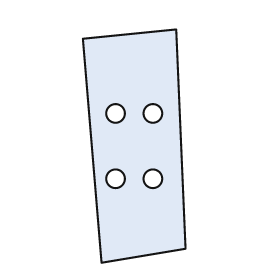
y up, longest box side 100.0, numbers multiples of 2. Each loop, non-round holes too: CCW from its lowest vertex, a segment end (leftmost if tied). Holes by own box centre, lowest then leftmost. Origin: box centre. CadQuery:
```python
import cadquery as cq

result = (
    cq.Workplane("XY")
    .moveTo(-14.0, -50.0)
    .lineTo(22.0, -44.0)
    .lineTo(18.0, 50.0)
    .lineTo(-22.0, 46.0)
    .close()
    .moveTo(-8.0, -14.0)
    .circle(4.0)
    .moveTo(8.0, -14.0)
    .circle(4.0)
    .moveTo(-8.0, 14.0)
    .circle(4.0)
    .moveTo(8.0, 14.0)
    .circle(4.0)
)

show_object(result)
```